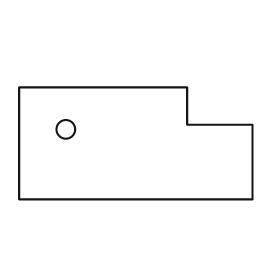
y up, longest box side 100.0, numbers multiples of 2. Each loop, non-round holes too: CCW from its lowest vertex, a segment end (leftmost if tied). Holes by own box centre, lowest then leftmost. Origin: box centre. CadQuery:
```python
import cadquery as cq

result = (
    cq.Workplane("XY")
    .moveTo(-50.0, -24.0)
    .lineTo(50.0, -24.0)
    .lineTo(50.0, 8.0)
    .lineTo(22.0, 8.0)
    .lineTo(22.0, 24.0)
    .lineTo(-50.0, 24.0)
    .close()
    .moveTo(-30.0, 6.0)
    .circle(4.0)
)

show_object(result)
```